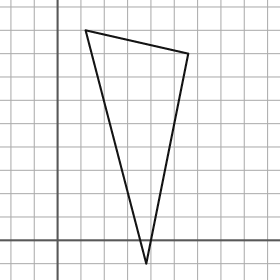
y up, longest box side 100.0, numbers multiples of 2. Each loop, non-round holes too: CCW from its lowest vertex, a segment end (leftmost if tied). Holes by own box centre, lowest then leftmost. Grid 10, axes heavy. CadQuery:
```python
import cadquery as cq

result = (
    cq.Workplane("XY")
    .moveTo(38.0, -10.0)
    .lineTo(56.0, 80.0)
    .lineTo(12.0, 90.0)
    .close()
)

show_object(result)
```